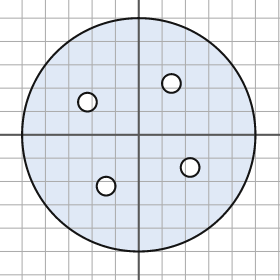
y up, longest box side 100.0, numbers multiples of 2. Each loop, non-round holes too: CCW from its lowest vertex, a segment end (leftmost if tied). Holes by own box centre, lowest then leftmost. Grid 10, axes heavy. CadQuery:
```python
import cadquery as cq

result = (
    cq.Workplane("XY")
    .moveTo(0.0, 0.0)
    .circle(50.0)
    .moveTo(-14.0, -22.0)
    .circle(4.0)
    .moveTo(22.0, -14.0)
    .circle(4.0)
    .moveTo(-22.0, 14.0)
    .circle(4.0)
    .moveTo(14.0, 22.0)
    .circle(4.0)
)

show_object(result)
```